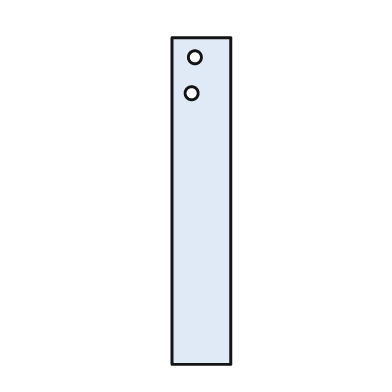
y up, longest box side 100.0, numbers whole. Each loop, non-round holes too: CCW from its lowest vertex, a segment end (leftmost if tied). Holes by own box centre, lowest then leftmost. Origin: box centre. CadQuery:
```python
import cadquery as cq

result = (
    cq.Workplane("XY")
    .moveTo(-9.0, -50.0)
    .lineTo(9.0, -50.0)
    .lineTo(9.0, 50.0)
    .lineTo(-9.0, 50.0)
    .close()
    .moveTo(-3.0, 33.0)
    .circle(2.0)
    .moveTo(-2.0, 44.0)
    .circle(2.0)
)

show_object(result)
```